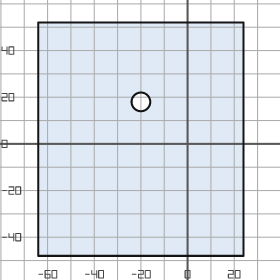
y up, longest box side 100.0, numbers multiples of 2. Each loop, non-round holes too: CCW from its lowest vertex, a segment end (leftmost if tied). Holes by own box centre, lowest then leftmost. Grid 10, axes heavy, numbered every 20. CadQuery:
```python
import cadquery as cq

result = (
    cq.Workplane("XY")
    .moveTo(-64.0, -48.0)
    .lineTo(24.0, -48.0)
    .lineTo(24.0, 52.0)
    .lineTo(-64.0, 52.0)
    .close()
    .moveTo(-20.0, 18.0)
    .circle(4.0)
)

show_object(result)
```